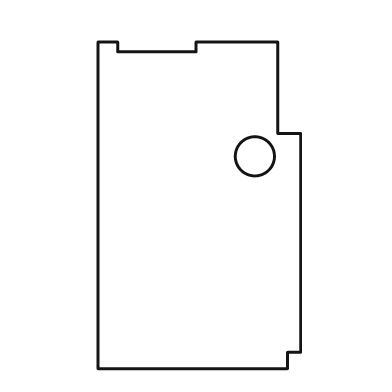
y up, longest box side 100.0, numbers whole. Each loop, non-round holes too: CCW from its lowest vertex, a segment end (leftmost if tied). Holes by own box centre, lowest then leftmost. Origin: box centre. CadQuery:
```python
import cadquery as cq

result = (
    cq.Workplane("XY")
    .moveTo(-31.0, -50.0)
    .lineTo(27.0, -50.0)
    .lineTo(27.0, -45.0)
    .lineTo(31.0, -45.0)
    .lineTo(31.0, 22.0)
    .lineTo(24.0, 22.0)
    .lineTo(24.0, 50.0)
    .lineTo(-1.0, 50.0)
    .lineTo(-1.0, 47.0)
    .lineTo(-25.0, 47.0)
    .lineTo(-25.0, 50.0)
    .lineTo(-31.0, 50.0)
    .close()
    .moveTo(17.0, 15.0)
    .circle(6.0)
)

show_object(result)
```